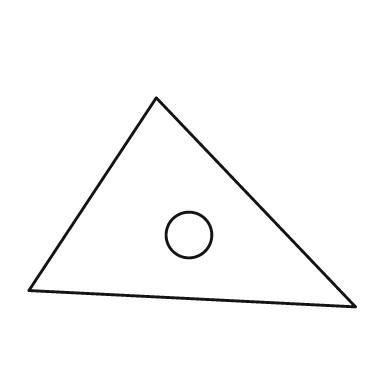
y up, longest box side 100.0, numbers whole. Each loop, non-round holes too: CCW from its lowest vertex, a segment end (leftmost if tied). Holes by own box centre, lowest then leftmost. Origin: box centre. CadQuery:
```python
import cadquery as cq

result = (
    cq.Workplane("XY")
    .moveTo(50.0, -32.0)
    .lineTo(-11.0, 32.0)
    .lineTo(-50.0, -27.0)
    .close()
    .moveTo(-1.0, -10.0)
    .circle(7.0)
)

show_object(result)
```